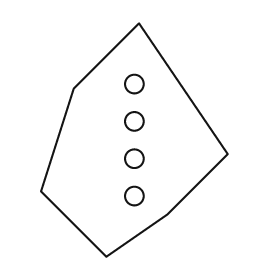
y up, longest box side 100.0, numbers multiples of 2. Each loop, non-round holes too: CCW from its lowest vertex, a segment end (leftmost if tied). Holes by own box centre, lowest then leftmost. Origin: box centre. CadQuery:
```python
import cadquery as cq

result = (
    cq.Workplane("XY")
    .moveTo(-12.0, -50.0)
    .lineTo(14.0, -32.0)
    .lineTo(40.0, -6.0)
    .lineTo(2.0, 50.0)
    .lineTo(-26.0, 22.0)
    .lineTo(-40.0, -22.0)
    .close()
    .moveTo(0.0, -24.0)
    .circle(4.0)
    .moveTo(0.0, -8.0)
    .circle(4.0)
    .moveTo(0.0, 8.0)
    .circle(4.0)
    .moveTo(0.0, 24.0)
    .circle(4.0)
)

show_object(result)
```